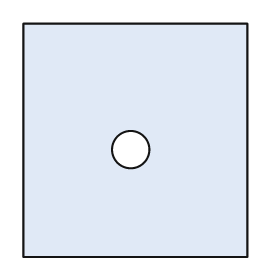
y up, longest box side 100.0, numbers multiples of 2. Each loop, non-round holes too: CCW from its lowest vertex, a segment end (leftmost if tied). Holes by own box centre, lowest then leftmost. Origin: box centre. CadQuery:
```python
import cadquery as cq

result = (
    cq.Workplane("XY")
    .moveTo(-48.0, -50.0)
    .lineTo(48.0, -50.0)
    .lineTo(48.0, 50.0)
    .lineTo(-48.0, 50.0)
    .close()
    .moveTo(-2.0, -4.0)
    .circle(8.0)
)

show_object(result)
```